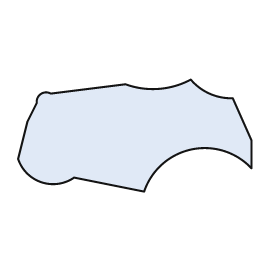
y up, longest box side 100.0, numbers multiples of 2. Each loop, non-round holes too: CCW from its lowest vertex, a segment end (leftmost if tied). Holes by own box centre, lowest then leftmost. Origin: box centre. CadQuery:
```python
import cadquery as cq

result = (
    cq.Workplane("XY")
    .moveTo(4.0, -24.0)
    .threePointArc((24.0, -6.0), (50.0, -14.0))
    .lineTo(50.0, -2.0)
    .lineTo(42.0, 16.0)
    .threePointArc((32.0, 18.0), (24.0, 24.0))
    .threePointArc((10.0, 20.0), (-4.0, 22.0))
    .lineTo(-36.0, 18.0)
    .threePointArc((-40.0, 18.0), (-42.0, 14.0))
    .lineTo(-46.0, 6.0)
    .lineTo(-50.0, -10.0)
    .threePointArc((-40.0, -20.0), (-26.0, -18.0))
    .close()
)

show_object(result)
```